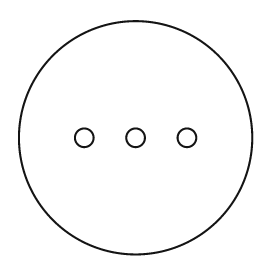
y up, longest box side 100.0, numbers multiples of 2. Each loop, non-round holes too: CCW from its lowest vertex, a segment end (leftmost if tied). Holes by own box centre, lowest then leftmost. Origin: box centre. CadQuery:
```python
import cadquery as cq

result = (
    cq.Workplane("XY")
    .moveTo(0.0, 0.0)
    .circle(50.0)
    .moveTo(-22.0, 0.0)
    .circle(4.0)
    .moveTo(0.0, 0.0)
    .circle(4.0)
    .moveTo(22.0, 0.0)
    .circle(4.0)
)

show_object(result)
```